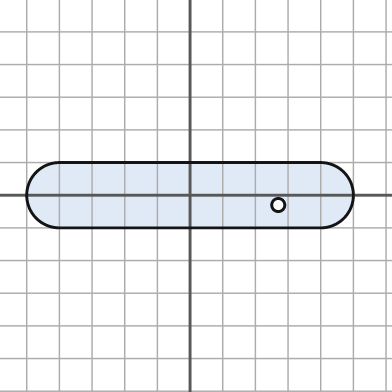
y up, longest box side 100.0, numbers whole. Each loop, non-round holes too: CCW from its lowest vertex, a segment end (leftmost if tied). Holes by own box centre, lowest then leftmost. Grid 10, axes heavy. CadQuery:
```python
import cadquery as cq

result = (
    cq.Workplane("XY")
    .moveTo(-40.0, -10.0)
    .lineTo(40.0, -10.0)
    .threePointArc((50.0, 0.0), (40.0, 10.0))
    .lineTo(-40.0, 10.0)
    .threePointArc((-50.0, 0.0), (-40.0, -10.0))
    .close()
    .moveTo(27.0, -3.0)
    .circle(2.0)
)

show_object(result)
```